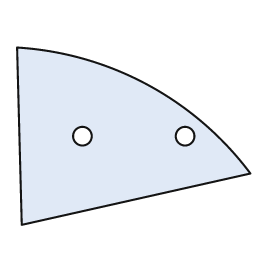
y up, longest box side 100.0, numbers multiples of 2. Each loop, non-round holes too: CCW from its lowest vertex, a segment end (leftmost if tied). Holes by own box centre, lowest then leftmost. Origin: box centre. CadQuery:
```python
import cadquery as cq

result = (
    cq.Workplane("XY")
    .moveTo(-48.0, -38.0)
    .lineTo(50.0, -16.0)
    .threePointArc((6.0, 22.0), (-50.0, 38.0))
    .close()
    .moveTo(-22.0, 0.0)
    .circle(4.0)
    .moveTo(22.0, 0.0)
    .circle(4.0)
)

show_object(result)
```